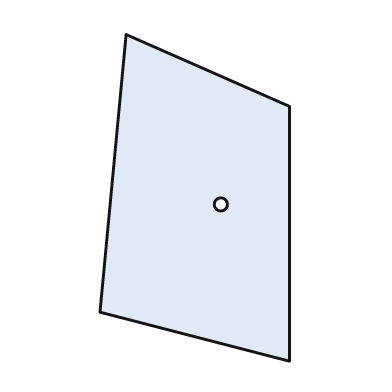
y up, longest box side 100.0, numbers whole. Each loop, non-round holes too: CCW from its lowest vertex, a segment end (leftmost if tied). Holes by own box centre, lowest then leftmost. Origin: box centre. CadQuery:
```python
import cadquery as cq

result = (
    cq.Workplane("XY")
    .moveTo(29.0, -50.0)
    .lineTo(29.0, 28.0)
    .lineTo(-21.0, 50.0)
    .lineTo(-29.0, -35.0)
    .close()
    .moveTo(8.0, -2.0)
    .circle(2.0)
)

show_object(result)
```